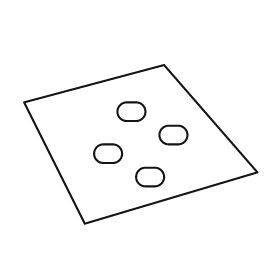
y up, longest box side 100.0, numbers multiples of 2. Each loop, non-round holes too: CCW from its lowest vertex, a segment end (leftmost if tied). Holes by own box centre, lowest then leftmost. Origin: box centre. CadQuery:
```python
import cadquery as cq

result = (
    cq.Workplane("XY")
    .moveTo(-24.0, -34.0)
    .lineTo(50.0, -12.0)
    .lineTo(10.0, 34.0)
    .lineTo(-50.0, 18.0)
    .close()
    .moveTo(2.0, -18.0)
    .lineTo(6.0, -18.0)
    .threePointArc((10.0, -14.0), (6.0, -10.0))
    .lineTo(2.0, -10.0)
    .threePointArc((-2.0, -14.0), (2.0, -18.0))
    .close()
    .moveTo(-16.0, -8.0)
    .lineTo(-12.0, -8.0)
    .threePointArc((-8.0, -4.0), (-12.0, 0.0))
    .lineTo(-16.0, 0.0)
    .threePointArc((-20.0, -4.0), (-16.0, -8.0))
    .close()
    .moveTo(12.0, 0.0)
    .lineTo(16.0, 0.0)
    .threePointArc((20.0, 4.0), (16.0, 8.0))
    .lineTo(12.0, 8.0)
    .threePointArc((8.0, 4.0), (12.0, 0.0))
    .close()
    .moveTo(-6.0, 10.0)
    .lineTo(-2.0, 10.0)
    .threePointArc((2.0, 14.0), (-2.0, 18.0))
    .lineTo(-6.0, 18.0)
    .threePointArc((-10.0, 14.0), (-6.0, 10.0))
    .close()
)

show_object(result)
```